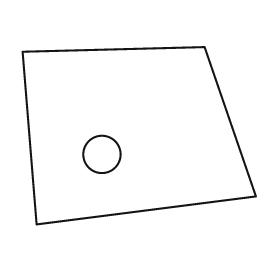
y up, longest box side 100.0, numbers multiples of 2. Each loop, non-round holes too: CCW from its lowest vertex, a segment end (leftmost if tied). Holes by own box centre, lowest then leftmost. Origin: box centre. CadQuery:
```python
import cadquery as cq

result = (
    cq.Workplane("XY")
    .moveTo(-44.0, -38.0)
    .lineTo(50.0, -26.0)
    .lineTo(28.0, 38.0)
    .lineTo(-50.0, 36.0)
    .close()
    .moveTo(-16.0, -8.0)
    .circle(8.0)
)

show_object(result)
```